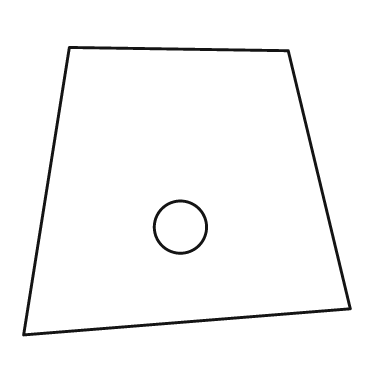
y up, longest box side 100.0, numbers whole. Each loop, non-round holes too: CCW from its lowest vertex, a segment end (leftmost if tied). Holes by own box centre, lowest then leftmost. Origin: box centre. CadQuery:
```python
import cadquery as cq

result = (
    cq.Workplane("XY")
    .moveTo(-50.0, -44.0)
    .lineTo(50.0, -36.0)
    .lineTo(31.0, 43.0)
    .lineTo(-36.0, 44.0)
    .close()
    .moveTo(-2.0, -11.0)
    .circle(8.0)
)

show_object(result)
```